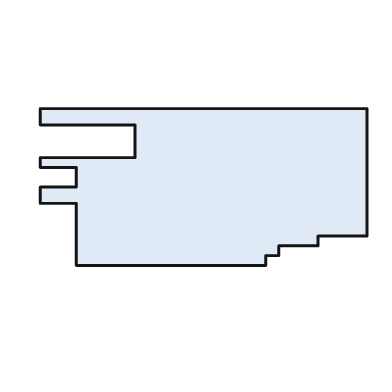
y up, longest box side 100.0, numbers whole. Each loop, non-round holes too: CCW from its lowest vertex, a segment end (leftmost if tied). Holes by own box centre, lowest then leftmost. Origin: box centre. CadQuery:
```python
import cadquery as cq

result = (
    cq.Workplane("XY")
    .moveTo(-39.0, -24.0)
    .lineTo(19.0, -24.0)
    .lineTo(19.0, -21.0)
    .lineTo(23.0, -21.0)
    .lineTo(23.0, -18.0)
    .lineTo(35.0, -18.0)
    .lineTo(35.0, -15.0)
    .lineTo(50.0, -15.0)
    .lineTo(50.0, 24.0)
    .lineTo(-50.0, 24.0)
    .lineTo(-50.0, 19.0)
    .lineTo(-21.0, 19.0)
    .lineTo(-21.0, 9.0)
    .lineTo(-50.0, 9.0)
    .lineTo(-50.0, 6.0)
    .lineTo(-39.0, 6.0)
    .lineTo(-39.0, 0.0)
    .lineTo(-50.0, 0.0)
    .lineTo(-50.0, -5.0)
    .lineTo(-39.0, -5.0)
    .close()
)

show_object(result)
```